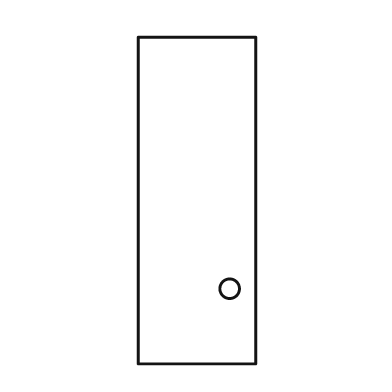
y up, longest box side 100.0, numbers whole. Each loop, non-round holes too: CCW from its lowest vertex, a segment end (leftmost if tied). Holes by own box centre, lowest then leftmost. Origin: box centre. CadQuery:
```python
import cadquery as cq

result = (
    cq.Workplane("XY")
    .moveTo(-18.0, -50.0)
    .lineTo(18.0, -50.0)
    .lineTo(18.0, 50.0)
    .lineTo(-18.0, 50.0)
    .close()
    .moveTo(10.0, -27.0)
    .circle(3.0)
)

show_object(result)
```